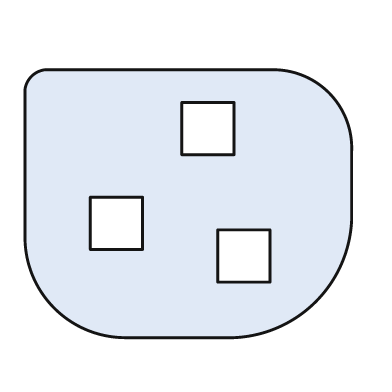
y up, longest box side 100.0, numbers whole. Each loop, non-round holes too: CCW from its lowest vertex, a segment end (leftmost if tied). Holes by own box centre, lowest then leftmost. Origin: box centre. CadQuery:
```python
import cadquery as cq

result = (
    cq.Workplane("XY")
    .moveTo(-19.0, -41.0)
    .lineTo(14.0, -41.0)
    .threePointArc((39.0, -30.0), (50.0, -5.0))
    .lineTo(50.0, 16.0)
    .threePointArc((43.0, 34.0), (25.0, 41.0))
    .lineTo(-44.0, 41.0)
    .threePointArc((-48.0, 39.0), (-50.0, 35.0))
    .lineTo(-50.0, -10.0)
    .threePointArc((-41.0, -32.0), (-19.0, -41.0))
    .close()
    .moveTo(9.0, -24.0)
    .lineTo(25.0, -24.0)
    .lineTo(25.0, -8.0)
    .lineTo(9.0, -8.0)
    .close()
    .moveTo(-30.0, -14.0)
    .lineTo(-14.0, -14.0)
    .lineTo(-14.0, 2.0)
    .lineTo(-30.0, 2.0)
    .close()
    .moveTo(-2.0, 15.0)
    .lineTo(14.0, 15.0)
    .lineTo(14.0, 31.0)
    .lineTo(-2.0, 31.0)
    .close()
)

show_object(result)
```